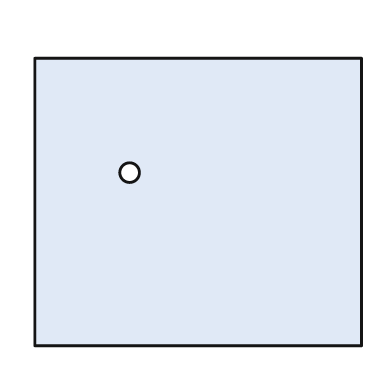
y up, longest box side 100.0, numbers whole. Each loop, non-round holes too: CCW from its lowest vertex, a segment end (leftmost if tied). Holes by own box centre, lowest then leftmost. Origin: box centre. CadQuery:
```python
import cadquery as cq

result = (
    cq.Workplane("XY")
    .moveTo(-50.0, -44.0)
    .lineTo(50.0, -44.0)
    .lineTo(50.0, 44.0)
    .lineTo(-50.0, 44.0)
    .close()
    .moveTo(-21.0, 9.0)
    .circle(3.0)
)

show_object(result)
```